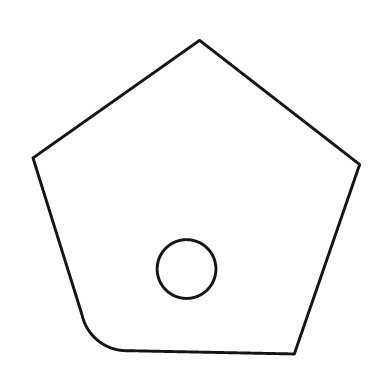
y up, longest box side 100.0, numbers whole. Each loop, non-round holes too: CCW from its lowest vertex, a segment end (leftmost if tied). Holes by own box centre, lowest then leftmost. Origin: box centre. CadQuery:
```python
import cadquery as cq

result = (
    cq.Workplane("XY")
    .moveTo(30.0, -48.0)
    .lineTo(50.0, 10.0)
    .lineTo(1.0, 48.0)
    .lineTo(-50.0, 12.0)
    .lineTo(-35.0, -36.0)
    .threePointArc((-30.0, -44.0), (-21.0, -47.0))
    .close()
    .moveTo(-3.0, -22.0)
    .circle(9.0)
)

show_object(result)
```